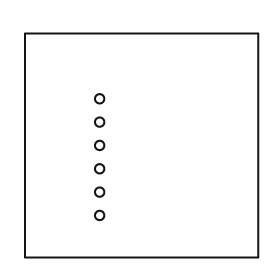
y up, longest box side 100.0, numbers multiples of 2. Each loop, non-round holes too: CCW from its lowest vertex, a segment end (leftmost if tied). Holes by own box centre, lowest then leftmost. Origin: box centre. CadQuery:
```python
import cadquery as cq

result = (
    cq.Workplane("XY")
    .moveTo(-50.0, -48.0)
    .lineTo(50.0, -48.0)
    .lineTo(50.0, 48.0)
    .lineTo(-50.0, 48.0)
    .close()
    .moveTo(-18.0, -30.0)
    .circle(2.0)
    .moveTo(-18.0, -20.0)
    .circle(2.0)
    .moveTo(-18.0, -10.0)
    .circle(2.0)
    .moveTo(-18.0, 0.0)
    .circle(2.0)
    .moveTo(-18.0, 10.0)
    .circle(2.0)
    .moveTo(-18.0, 20.0)
    .circle(2.0)
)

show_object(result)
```